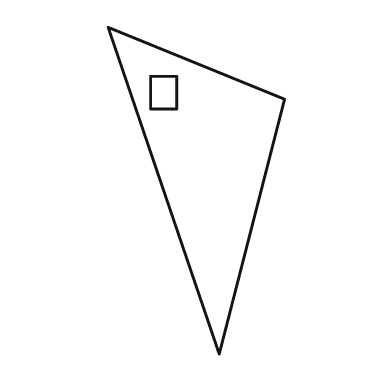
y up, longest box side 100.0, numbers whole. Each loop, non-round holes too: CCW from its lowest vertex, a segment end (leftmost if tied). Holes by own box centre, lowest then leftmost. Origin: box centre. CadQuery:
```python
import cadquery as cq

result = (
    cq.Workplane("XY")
    .moveTo(7.0, -50.0)
    .lineTo(27.0, 28.0)
    .lineTo(-27.0, 50.0)
    .close()
    .moveTo(-14.0, 25.0)
    .lineTo(-6.0, 25.0)
    .lineTo(-6.0, 35.0)
    .lineTo(-14.0, 35.0)
    .close()
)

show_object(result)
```